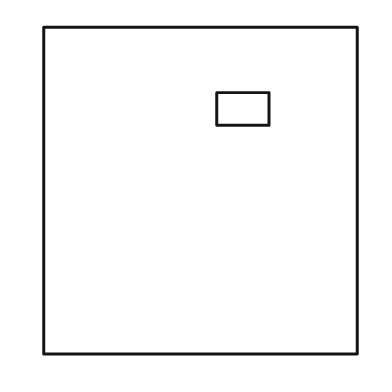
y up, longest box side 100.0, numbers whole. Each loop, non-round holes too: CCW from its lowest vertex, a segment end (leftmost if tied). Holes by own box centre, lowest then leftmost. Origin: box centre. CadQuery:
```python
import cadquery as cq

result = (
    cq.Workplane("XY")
    .moveTo(-48.0, -50.0)
    .lineTo(48.0, -50.0)
    .lineTo(48.0, 50.0)
    .lineTo(-48.0, 50.0)
    .close()
    .moveTo(5.0, 20.0)
    .lineTo(21.0, 20.0)
    .lineTo(21.0, 30.0)
    .lineTo(5.0, 30.0)
    .close()
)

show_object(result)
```